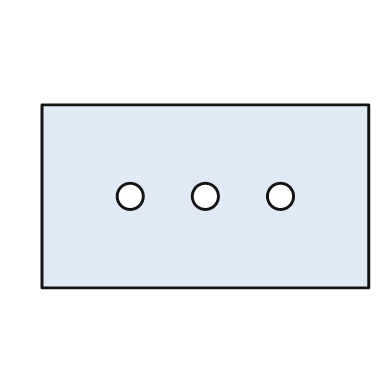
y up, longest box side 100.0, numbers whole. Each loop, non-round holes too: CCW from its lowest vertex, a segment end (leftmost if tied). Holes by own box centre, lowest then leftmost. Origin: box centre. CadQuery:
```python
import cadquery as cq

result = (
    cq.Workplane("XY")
    .moveTo(-50.0, -28.0)
    .lineTo(50.0, -28.0)
    .lineTo(50.0, 28.0)
    .lineTo(-50.0, 28.0)
    .close()
    .moveTo(-23.0, 0.0)
    .circle(4.0)
    .moveTo(0.0, 0.0)
    .circle(4.0)
    .moveTo(23.0, 0.0)
    .circle(4.0)
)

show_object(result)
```